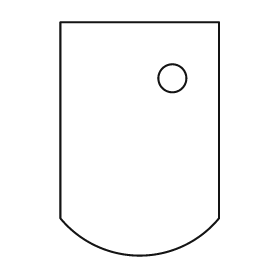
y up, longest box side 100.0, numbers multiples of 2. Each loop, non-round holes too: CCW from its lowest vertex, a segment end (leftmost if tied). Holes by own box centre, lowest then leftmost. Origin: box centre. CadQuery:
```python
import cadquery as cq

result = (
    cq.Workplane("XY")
    .moveTo(-34.0, -34.0)
    .threePointArc((0.0, -50.0), (34.0, -34.0))
    .lineTo(34.0, 50.0)
    .lineTo(-34.0, 50.0)
    .close()
    .moveTo(14.0, 26.0)
    .circle(6.0)
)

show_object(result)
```